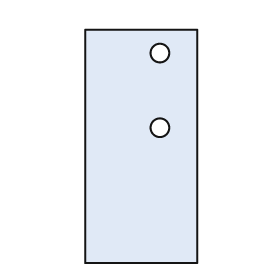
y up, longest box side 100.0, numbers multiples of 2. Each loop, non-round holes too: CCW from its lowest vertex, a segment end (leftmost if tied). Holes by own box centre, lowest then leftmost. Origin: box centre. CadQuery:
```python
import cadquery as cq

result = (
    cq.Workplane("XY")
    .moveTo(-24.0, -50.0)
    .lineTo(24.0, -50.0)
    .lineTo(24.0, 50.0)
    .lineTo(-24.0, 50.0)
    .close()
    .moveTo(8.0, 8.0)
    .circle(4.0)
    .moveTo(8.0, 40.0)
    .circle(4.0)
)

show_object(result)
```